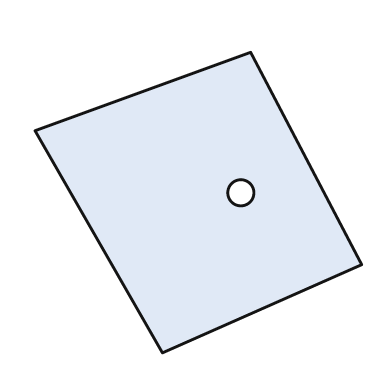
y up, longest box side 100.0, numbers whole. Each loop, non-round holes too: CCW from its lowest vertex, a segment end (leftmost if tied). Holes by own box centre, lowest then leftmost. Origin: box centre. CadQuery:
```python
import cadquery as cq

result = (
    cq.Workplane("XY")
    .moveTo(-11.0, -46.0)
    .lineTo(50.0, -19.0)
    .lineTo(16.0, 46.0)
    .lineTo(-50.0, 22.0)
    .close()
    .moveTo(13.0, 3.0)
    .circle(4.0)
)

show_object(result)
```